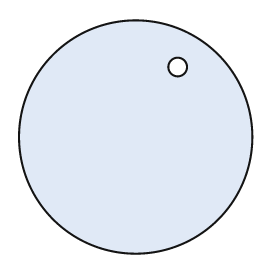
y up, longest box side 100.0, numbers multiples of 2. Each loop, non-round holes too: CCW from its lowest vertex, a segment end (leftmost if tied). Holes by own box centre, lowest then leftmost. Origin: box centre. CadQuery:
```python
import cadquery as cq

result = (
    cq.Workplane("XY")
    .moveTo(0.0, 0.0)
    .circle(50.0)
    .moveTo(18.0, 30.0)
    .circle(4.0)
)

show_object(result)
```